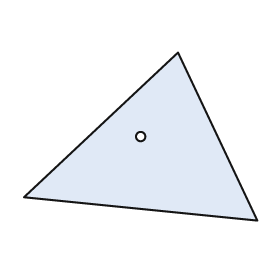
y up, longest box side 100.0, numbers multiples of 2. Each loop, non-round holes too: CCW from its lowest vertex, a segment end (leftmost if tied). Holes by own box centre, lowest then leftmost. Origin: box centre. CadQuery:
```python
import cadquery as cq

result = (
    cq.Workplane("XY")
    .moveTo(50.0, -36.0)
    .lineTo(16.0, 36.0)
    .lineTo(-50.0, -26.0)
    .close()
    .moveTo(0.0, 0.0)
    .circle(2.0)
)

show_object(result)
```